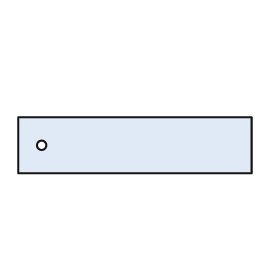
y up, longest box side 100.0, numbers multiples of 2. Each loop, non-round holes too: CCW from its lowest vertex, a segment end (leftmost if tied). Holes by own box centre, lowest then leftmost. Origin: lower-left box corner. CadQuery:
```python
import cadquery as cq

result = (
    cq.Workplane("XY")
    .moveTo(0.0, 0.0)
    .lineTo(100.0, 0.0)
    .lineTo(100.0, 24.0)
    .lineTo(0.0, 24.0)
    .close()
    .moveTo(10.0, 12.0)
    .circle(2.0)
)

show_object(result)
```